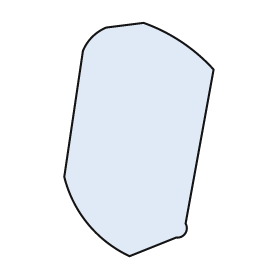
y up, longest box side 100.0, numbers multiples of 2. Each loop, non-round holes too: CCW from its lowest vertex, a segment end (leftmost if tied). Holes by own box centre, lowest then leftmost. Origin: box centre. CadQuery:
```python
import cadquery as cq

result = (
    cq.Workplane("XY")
    .moveTo(-4.0, -50.0)
    .lineTo(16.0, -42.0)
    .threePointArc((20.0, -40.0), (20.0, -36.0))
    .lineTo(32.0, 30.0)
    .threePointArc((18.0, 42.0), (2.0, 50.0))
    .lineTo(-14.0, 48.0)
    .threePointArc((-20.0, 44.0), (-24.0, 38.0))
    .lineTo(-32.0, -16.0)
    .threePointArc((-22.0, -36.0), (-4.0, -50.0))
    .close()
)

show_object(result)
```